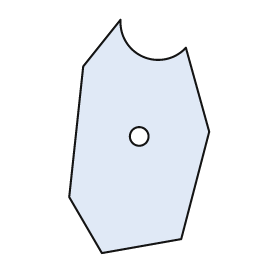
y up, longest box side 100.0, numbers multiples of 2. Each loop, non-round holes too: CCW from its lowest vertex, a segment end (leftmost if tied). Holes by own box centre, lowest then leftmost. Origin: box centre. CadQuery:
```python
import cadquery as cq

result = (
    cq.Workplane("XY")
    .moveTo(-16.0, -50.0)
    .lineTo(18.0, -44.0)
    .lineTo(30.0, 2.0)
    .lineTo(20.0, 38.0)
    .threePointArc((2.0, 34.0), (-8.0, 50.0))
    .lineTo(-24.0, 30.0)
    .lineTo(-30.0, -26.0)
    .close()
    .moveTo(0.0, 0.0)
    .circle(4.0)
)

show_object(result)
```